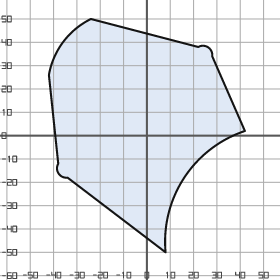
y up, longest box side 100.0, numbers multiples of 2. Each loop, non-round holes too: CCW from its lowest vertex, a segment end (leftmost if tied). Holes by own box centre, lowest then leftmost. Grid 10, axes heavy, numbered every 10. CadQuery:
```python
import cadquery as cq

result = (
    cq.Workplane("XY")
    .moveTo(8.0, -50.0)
    .threePointArc((16.0, -18.0), (42.0, 2.0))
    .lineTo(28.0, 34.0)
    .threePointArc((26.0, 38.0), (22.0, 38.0))
    .lineTo(-24.0, 50.0)
    .threePointArc((-36.0, 40.0), (-42.0, 26.0))
    .lineTo(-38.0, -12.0)
    .threePointArc((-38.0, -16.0), (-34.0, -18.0))
    .close()
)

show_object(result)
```